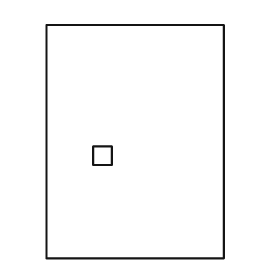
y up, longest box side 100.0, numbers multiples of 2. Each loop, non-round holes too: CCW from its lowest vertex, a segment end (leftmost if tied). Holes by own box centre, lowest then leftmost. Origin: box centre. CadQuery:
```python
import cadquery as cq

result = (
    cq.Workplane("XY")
    .moveTo(-38.0, -50.0)
    .lineTo(38.0, -50.0)
    .lineTo(38.0, 50.0)
    .lineTo(-38.0, 50.0)
    .close()
    .moveTo(-18.0, -10.0)
    .lineTo(-10.0, -10.0)
    .lineTo(-10.0, -2.0)
    .lineTo(-18.0, -2.0)
    .close()
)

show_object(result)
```